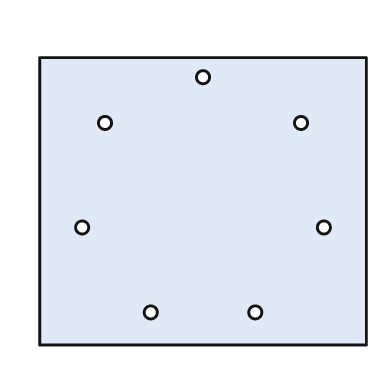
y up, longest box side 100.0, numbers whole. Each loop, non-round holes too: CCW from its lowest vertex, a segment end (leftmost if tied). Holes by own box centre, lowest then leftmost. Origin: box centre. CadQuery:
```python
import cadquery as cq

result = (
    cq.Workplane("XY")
    .moveTo(-50.0, -44.0)
    .lineTo(50.0, -44.0)
    .lineTo(50.0, 44.0)
    .lineTo(-50.0, 44.0)
    .close()
    .moveTo(-16.0, -34.0)
    .circle(2.0)
    .moveTo(16.0, -34.0)
    .circle(2.0)
    .moveTo(-37.0, -8.0)
    .circle(2.0)
    .moveTo(37.0, -8.0)
    .circle(2.0)
    .moveTo(-30.0, 24.0)
    .circle(2.0)
    .moveTo(30.0, 24.0)
    .circle(2.0)
    .moveTo(0.0, 38.0)
    .circle(2.0)
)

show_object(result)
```